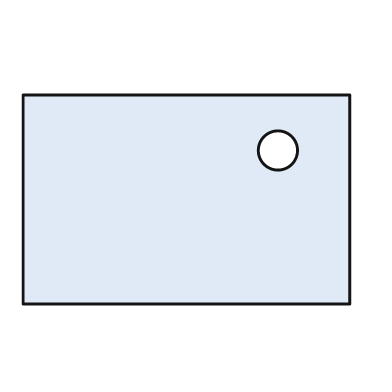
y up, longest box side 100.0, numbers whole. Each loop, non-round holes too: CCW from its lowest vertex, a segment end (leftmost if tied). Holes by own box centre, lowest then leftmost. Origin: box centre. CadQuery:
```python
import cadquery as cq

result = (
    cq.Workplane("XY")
    .moveTo(-50.0, -32.0)
    .lineTo(50.0, -32.0)
    .lineTo(50.0, 32.0)
    .lineTo(-50.0, 32.0)
    .close()
    .moveTo(28.0, 15.0)
    .circle(6.0)
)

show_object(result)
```